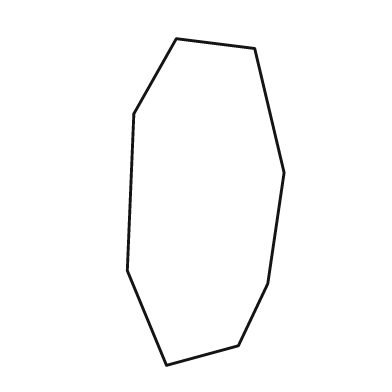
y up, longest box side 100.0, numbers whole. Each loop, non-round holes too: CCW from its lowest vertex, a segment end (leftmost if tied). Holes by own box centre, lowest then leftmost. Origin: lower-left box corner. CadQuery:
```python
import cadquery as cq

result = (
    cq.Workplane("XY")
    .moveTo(12.0, 0.0)
    .lineTo(34.0, 6.0)
    .lineTo(43.0, 25.0)
    .lineTo(48.0, 59.0)
    .lineTo(39.0, 97.0)
    .lineTo(15.0, 100.0)
    .lineTo(2.0, 77.0)
    .lineTo(0.0, 29.0)
    .close()
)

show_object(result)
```